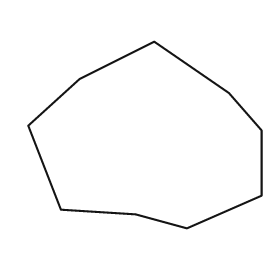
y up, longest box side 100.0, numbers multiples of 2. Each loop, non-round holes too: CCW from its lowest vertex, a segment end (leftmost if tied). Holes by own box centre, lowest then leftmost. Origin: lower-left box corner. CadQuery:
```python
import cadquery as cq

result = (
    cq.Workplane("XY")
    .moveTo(68.0, 0.0)
    .lineTo(100.0, 14.0)
    .lineTo(100.0, 42.0)
    .lineTo(86.0, 58.0)
    .lineTo(54.0, 80.0)
    .lineTo(22.0, 64.0)
    .lineTo(0.0, 44.0)
    .lineTo(14.0, 8.0)
    .lineTo(46.0, 6.0)
    .close()
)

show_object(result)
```